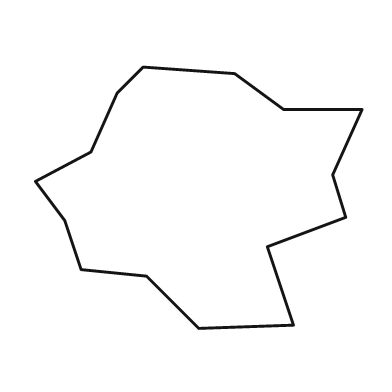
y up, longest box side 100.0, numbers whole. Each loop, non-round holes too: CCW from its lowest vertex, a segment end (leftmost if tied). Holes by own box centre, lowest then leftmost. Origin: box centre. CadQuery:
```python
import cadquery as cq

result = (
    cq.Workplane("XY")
    .moveTo(0.0, -40.0)
    .lineTo(29.0, -39.0)
    .lineTo(21.0, -15.0)
    .lineTo(45.0, -6.0)
    .lineTo(41.0, 7.0)
    .lineTo(50.0, 27.0)
    .lineTo(26.0, 27.0)
    .lineTo(11.0, 38.0)
    .lineTo(-17.0, 40.0)
    .lineTo(-25.0, 32.0)
    .lineTo(-33.0, 14.0)
    .lineTo(-50.0, 5.0)
    .lineTo(-41.0, -7.0)
    .lineTo(-36.0, -22.0)
    .lineTo(-16.0, -24.0)
    .close()
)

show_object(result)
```